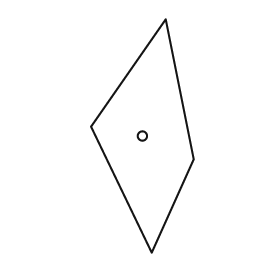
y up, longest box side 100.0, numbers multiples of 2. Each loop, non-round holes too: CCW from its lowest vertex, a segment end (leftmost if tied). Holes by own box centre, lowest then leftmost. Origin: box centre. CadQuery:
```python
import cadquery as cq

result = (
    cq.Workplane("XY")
    .moveTo(4.0, -50.0)
    .lineTo(22.0, -10.0)
    .lineTo(10.0, 50.0)
    .lineTo(-22.0, 4.0)
    .close()
    .moveTo(0.0, 0.0)
    .circle(2.0)
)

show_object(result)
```